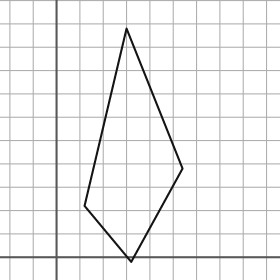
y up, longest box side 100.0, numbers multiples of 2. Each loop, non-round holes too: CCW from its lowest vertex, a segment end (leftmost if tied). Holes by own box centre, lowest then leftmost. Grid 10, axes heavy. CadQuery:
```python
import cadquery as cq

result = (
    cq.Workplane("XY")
    .moveTo(32.0, -2.0)
    .lineTo(54.0, 38.0)
    .lineTo(30.0, 98.0)
    .lineTo(12.0, 22.0)
    .close()
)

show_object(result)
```